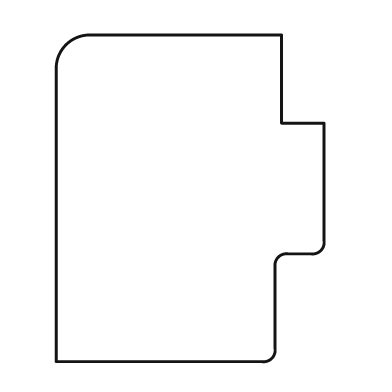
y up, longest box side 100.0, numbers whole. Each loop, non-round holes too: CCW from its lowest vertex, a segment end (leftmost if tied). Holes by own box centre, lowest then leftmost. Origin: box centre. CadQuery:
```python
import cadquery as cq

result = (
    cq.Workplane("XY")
    .moveTo(-41.0, -50.0)
    .lineTo(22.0, -50.0)
    .threePointArc((25.0, -49.0), (26.0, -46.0))
    .lineTo(26.0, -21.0)
    .threePointArc((27.0, -18.0), (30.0, -17.0))
    .lineTo(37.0, -17.0)
    .threePointArc((40.0, -16.0), (41.0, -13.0))
    .lineTo(41.0, 23.0)
    .lineTo(28.0, 23.0)
    .lineTo(28.0, 50.0)
    .lineTo(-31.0, 50.0)
    .threePointArc((-38.0, 47.0), (-41.0, 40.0))
    .close()
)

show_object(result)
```